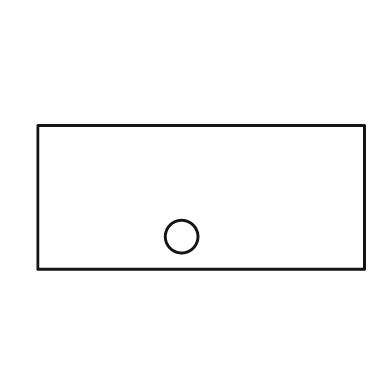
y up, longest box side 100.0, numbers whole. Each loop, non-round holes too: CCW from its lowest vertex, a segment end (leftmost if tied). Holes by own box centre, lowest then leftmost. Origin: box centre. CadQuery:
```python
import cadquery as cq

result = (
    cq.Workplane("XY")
    .moveTo(-50.0, -22.0)
    .lineTo(50.0, -22.0)
    .lineTo(50.0, 22.0)
    .lineTo(-50.0, 22.0)
    .close()
    .moveTo(-6.0, -12.0)
    .circle(5.0)
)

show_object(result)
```